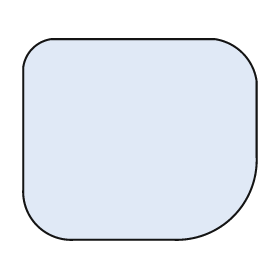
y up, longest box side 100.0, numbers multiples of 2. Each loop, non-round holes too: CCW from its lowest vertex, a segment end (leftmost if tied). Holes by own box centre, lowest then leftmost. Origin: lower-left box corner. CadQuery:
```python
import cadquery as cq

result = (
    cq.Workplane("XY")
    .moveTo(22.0, 0.0)
    .lineTo(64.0, 0.0)
    .threePointArc((90.0, 10.0), (100.0, 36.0))
    .lineTo(100.0, 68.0)
    .threePointArc((94.0, 80.0), (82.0, 86.0))
    .lineTo(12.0, 86.0)
    .threePointArc((4.0, 82.0), (0.0, 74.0))
    .lineTo(0.0, 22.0)
    .threePointArc((6.0, 6.0), (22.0, 0.0))
    .close()
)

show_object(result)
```